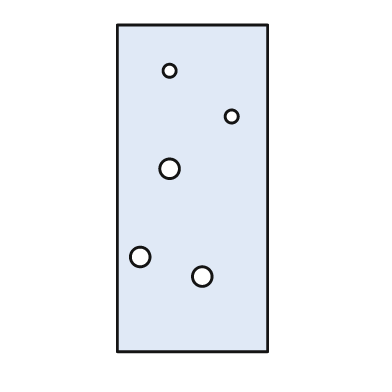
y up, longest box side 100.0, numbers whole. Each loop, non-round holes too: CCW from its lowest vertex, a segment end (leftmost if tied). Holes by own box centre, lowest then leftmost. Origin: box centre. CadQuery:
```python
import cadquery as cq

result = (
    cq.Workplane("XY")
    .moveTo(-23.0, -50.0)
    .lineTo(23.0, -50.0)
    .lineTo(23.0, 50.0)
    .lineTo(-23.0, 50.0)
    .close()
    .moveTo(3.0, -27.0)
    .circle(3.0)
    .moveTo(-16.0, -21.0)
    .circle(3.0)
    .moveTo(-7.0, 6.0)
    .circle(3.0)
    .moveTo(12.0, 22.0)
    .circle(2.0)
    .moveTo(-7.0, 36.0)
    .circle(2.0)
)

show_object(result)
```